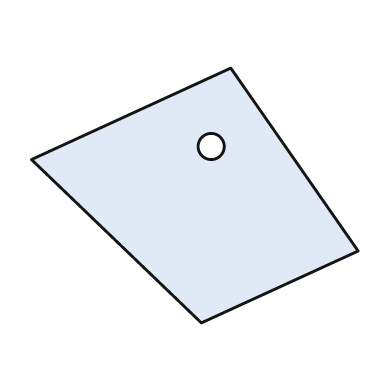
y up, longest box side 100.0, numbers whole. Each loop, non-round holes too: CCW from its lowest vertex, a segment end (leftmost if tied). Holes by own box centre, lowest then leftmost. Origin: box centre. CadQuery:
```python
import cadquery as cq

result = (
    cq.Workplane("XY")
    .moveTo(2.0, -39.0)
    .lineTo(50.0, -17.0)
    .lineTo(11.0, 39.0)
    .lineTo(-50.0, 11.0)
    .close()
    .moveTo(5.0, 15.0)
    .circle(4.0)
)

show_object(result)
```